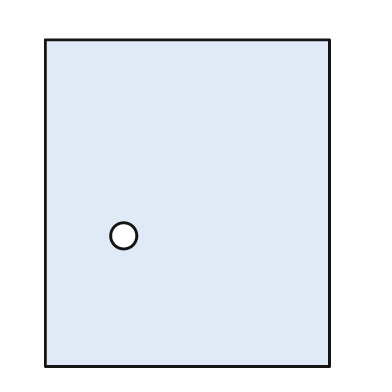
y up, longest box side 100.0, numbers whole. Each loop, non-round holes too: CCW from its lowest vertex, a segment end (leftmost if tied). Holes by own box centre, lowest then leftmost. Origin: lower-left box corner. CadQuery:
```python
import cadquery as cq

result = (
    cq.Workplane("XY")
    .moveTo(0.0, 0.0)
    .lineTo(87.0, 0.0)
    .lineTo(87.0, 100.0)
    .lineTo(0.0, 100.0)
    .close()
    .moveTo(24.0, 40.0)
    .circle(4.0)
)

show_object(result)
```